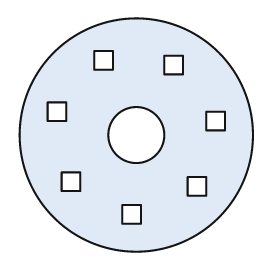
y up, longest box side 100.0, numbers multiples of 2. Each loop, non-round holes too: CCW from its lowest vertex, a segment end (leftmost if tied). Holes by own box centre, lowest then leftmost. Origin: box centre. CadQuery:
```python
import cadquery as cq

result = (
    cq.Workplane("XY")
    .moveTo(0.0, 0.0)
    .circle(50.0)
    .moveTo(-6.0, -38.0)
    .lineTo(2.0, -38.0)
    .lineTo(2.0, -30.0)
    .lineTo(-6.0, -30.0)
    .close()
    .moveTo(22.0, -26.0)
    .lineTo(30.0, -26.0)
    .lineTo(30.0, -18.0)
    .lineTo(22.0, -18.0)
    .close()
    .moveTo(-32.0, -24.0)
    .lineTo(-24.0, -24.0)
    .lineTo(-24.0, -16.0)
    .lineTo(-32.0, -16.0)
    .close()
    .moveTo(0.0, 0.0)
    .circle(12.0)
    .moveTo(30.0, 2.0)
    .lineTo(38.0, 2.0)
    .lineTo(38.0, 10.0)
    .lineTo(30.0, 10.0)
    .close()
    .moveTo(-38.0, 6.0)
    .lineTo(-30.0, 6.0)
    .lineTo(-30.0, 14.0)
    .lineTo(-38.0, 14.0)
    .close()
    .moveTo(12.0, 26.0)
    .lineTo(20.0, 26.0)
    .lineTo(20.0, 34.0)
    .lineTo(12.0, 34.0)
    .close()
    .moveTo(-18.0, 28.0)
    .lineTo(-10.0, 28.0)
    .lineTo(-10.0, 36.0)
    .lineTo(-18.0, 36.0)
    .close()
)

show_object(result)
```